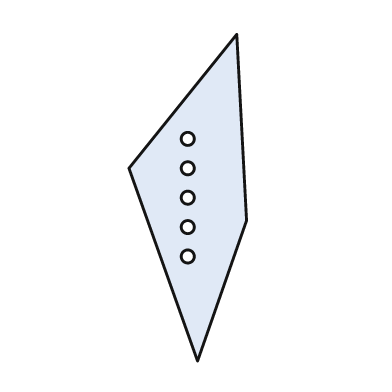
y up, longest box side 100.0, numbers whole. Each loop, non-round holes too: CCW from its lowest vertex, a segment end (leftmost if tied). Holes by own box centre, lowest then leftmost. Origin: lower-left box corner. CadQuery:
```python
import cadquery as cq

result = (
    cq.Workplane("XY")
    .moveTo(21.0, 0.0)
    .lineTo(36.0, 43.0)
    .lineTo(33.0, 100.0)
    .lineTo(0.0, 59.0)
    .close()
    .moveTo(18.0, 32.0)
    .circle(2.0)
    .moveTo(18.0, 41.0)
    .circle(2.0)
    .moveTo(18.0, 50.0)
    .circle(2.0)
    .moveTo(18.0, 59.0)
    .circle(2.0)
    .moveTo(18.0, 68.0)
    .circle(2.0)
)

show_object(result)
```